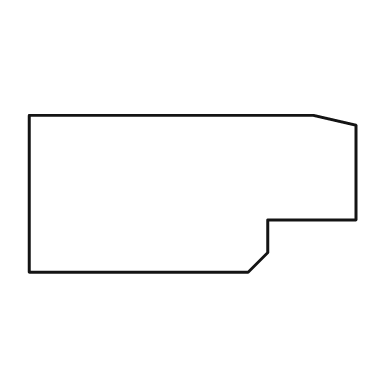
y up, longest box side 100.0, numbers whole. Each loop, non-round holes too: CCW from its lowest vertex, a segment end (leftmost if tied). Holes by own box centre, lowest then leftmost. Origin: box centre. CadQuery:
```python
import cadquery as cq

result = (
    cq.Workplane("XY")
    .moveTo(-50.0, -24.0)
    .lineTo(17.0, -24.0)
    .lineTo(23.0, -18.0)
    .lineTo(23.0, -8.0)
    .lineTo(50.0, -8.0)
    .lineTo(50.0, 21.0)
    .lineTo(37.0, 24.0)
    .lineTo(-50.0, 24.0)
    .close()
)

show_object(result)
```